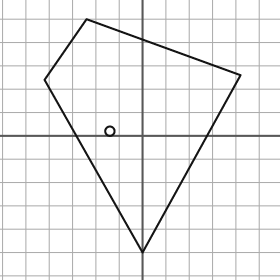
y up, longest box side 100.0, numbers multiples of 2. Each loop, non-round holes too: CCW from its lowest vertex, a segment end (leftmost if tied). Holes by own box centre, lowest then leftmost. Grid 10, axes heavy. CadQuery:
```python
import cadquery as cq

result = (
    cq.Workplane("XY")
    .moveTo(0.0, -50.0)
    .lineTo(42.0, 26.0)
    .lineTo(-24.0, 50.0)
    .lineTo(-42.0, 24.0)
    .close()
    .moveTo(-14.0, 2.0)
    .circle(2.0)
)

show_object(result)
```